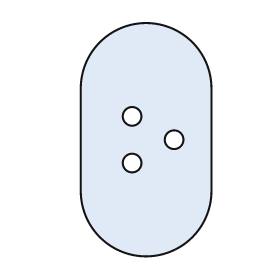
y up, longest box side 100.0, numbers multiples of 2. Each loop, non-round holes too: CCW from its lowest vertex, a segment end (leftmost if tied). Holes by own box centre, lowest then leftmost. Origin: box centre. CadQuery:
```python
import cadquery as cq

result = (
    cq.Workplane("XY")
    .moveTo(-28.0, -22.0)
    .threePointArc((0.0, -50.0), (28.0, -22.0))
    .lineTo(28.0, 22.0)
    .threePointArc((0.0, 50.0), (-28.0, 22.0))
    .close()
    .moveTo(-6.0, -10.0)
    .circle(4.0)
    .moveTo(12.0, 0.0)
    .circle(4.0)
    .moveTo(-6.0, 10.0)
    .circle(4.0)
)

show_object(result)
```